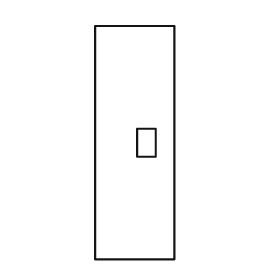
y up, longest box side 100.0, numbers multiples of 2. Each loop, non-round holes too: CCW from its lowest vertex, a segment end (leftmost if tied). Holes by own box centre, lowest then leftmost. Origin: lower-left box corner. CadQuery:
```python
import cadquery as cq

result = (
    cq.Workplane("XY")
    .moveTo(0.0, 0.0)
    .lineTo(34.0, 0.0)
    .lineTo(34.0, 100.0)
    .lineTo(0.0, 100.0)
    .close()
    .moveTo(18.0, 44.0)
    .lineTo(26.0, 44.0)
    .lineTo(26.0, 56.0)
    .lineTo(18.0, 56.0)
    .close()
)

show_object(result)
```